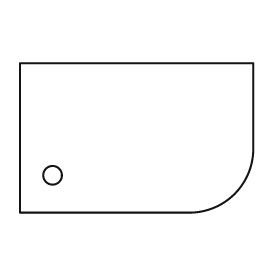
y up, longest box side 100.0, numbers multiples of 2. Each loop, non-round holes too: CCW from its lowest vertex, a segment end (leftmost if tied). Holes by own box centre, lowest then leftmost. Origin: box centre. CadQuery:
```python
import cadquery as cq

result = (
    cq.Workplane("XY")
    .moveTo(-50.0, -32.0)
    .lineTo(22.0, -32.0)
    .threePointArc((42.0, -24.0), (50.0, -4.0))
    .lineTo(50.0, 32.0)
    .lineTo(-50.0, 32.0)
    .close()
    .moveTo(-36.0, -16.0)
    .circle(4.0)
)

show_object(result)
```